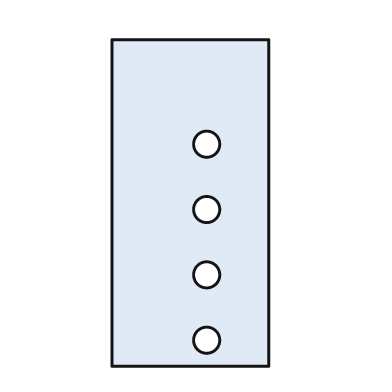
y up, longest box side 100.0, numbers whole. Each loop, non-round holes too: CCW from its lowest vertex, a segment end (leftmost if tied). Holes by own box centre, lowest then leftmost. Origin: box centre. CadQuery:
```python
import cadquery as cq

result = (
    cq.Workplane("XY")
    .moveTo(-24.0, -50.0)
    .lineTo(24.0, -50.0)
    .lineTo(24.0, 50.0)
    .lineTo(-24.0, 50.0)
    .close()
    .moveTo(5.0, -42.0)
    .circle(4.0)
    .moveTo(5.0, -22.0)
    .circle(4.0)
    .moveTo(5.0, -2.0)
    .circle(4.0)
    .moveTo(5.0, 18.0)
    .circle(4.0)
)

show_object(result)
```